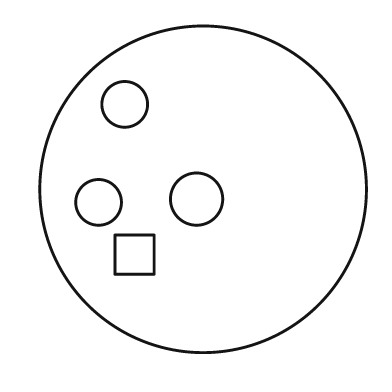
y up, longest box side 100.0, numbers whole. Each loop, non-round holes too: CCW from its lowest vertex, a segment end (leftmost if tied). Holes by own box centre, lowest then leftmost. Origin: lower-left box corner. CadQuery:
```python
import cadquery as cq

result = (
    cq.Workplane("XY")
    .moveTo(50.0, 50.0)
    .circle(50.0)
    .moveTo(23.0, 24.0)
    .lineTo(35.0, 24.0)
    .lineTo(35.0, 36.0)
    .lineTo(23.0, 36.0)
    .close()
    .moveTo(18.0, 46.0)
    .circle(7.0)
    .moveTo(48.0, 47.0)
    .circle(8.0)
    .moveTo(26.0, 76.0)
    .circle(7.0)
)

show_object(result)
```